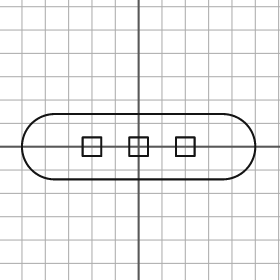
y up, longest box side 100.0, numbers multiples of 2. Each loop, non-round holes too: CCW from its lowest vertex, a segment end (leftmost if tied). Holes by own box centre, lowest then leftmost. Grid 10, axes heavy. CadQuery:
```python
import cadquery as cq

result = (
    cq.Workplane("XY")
    .moveTo(-36.0, -14.0)
    .lineTo(36.0, -14.0)
    .threePointArc((50.0, 0.0), (36.0, 14.0))
    .lineTo(-36.0, 14.0)
    .threePointArc((-50.0, 0.0), (-36.0, -14.0))
    .close()
    .moveTo(-24.0, -4.0)
    .lineTo(-16.0, -4.0)
    .lineTo(-16.0, 4.0)
    .lineTo(-24.0, 4.0)
    .close()
    .moveTo(-4.0, -4.0)
    .lineTo(4.0, -4.0)
    .lineTo(4.0, 4.0)
    .lineTo(-4.0, 4.0)
    .close()
    .moveTo(16.0, -4.0)
    .lineTo(24.0, -4.0)
    .lineTo(24.0, 4.0)
    .lineTo(16.0, 4.0)
    .close()
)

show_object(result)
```